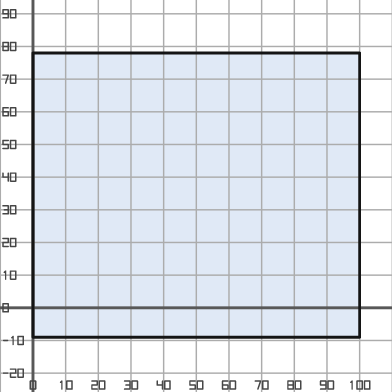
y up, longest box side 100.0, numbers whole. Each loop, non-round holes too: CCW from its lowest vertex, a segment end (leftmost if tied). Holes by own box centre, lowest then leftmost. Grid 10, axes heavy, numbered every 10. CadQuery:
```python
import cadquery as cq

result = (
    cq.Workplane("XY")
    .moveTo(0.0, -9.0)
    .lineTo(100.0, -9.0)
    .lineTo(100.0, 78.0)
    .lineTo(0.0, 78.0)
    .close()
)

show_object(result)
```